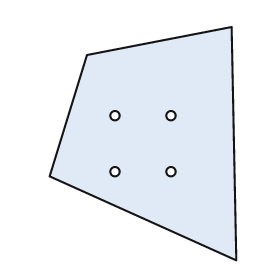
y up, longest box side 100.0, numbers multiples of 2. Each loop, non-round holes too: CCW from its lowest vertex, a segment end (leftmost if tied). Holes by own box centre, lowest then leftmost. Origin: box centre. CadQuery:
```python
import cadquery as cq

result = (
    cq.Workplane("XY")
    .moveTo(40.0, -50.0)
    .lineTo(38.0, 50.0)
    .lineTo(-24.0, 38.0)
    .lineTo(-40.0, -14.0)
    .close()
    .moveTo(-12.0, -12.0)
    .circle(2.0)
    .moveTo(12.0, -12.0)
    .circle(2.0)
    .moveTo(-12.0, 12.0)
    .circle(2.0)
    .moveTo(12.0, 12.0)
    .circle(2.0)
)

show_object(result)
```